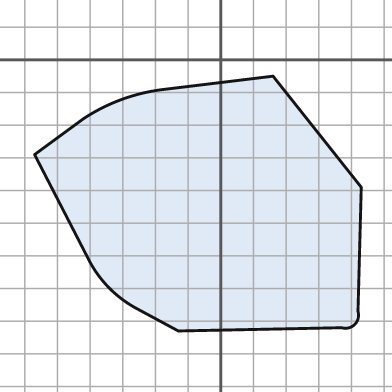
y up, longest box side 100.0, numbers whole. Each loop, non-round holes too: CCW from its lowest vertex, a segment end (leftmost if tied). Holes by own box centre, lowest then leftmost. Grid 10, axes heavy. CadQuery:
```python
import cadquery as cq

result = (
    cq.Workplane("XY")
    .moveTo(-13.0, -83.0)
    .lineTo(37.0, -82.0)
    .threePointArc((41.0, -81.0), (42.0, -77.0))
    .lineTo(43.0, -39.0)
    .lineTo(16.0, -5.0)
    .lineTo(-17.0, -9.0)
    .threePointArc((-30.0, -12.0), (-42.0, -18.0))
    .lineTo(-57.0, -29.0)
    .lineTo(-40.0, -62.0)
    .threePointArc((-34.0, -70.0), (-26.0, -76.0))
    .close()
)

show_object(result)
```